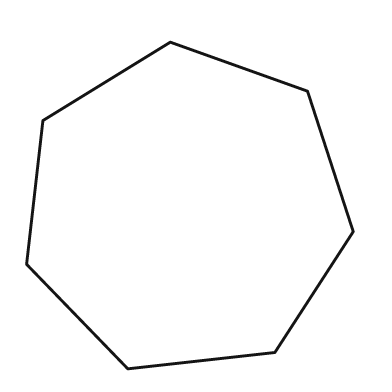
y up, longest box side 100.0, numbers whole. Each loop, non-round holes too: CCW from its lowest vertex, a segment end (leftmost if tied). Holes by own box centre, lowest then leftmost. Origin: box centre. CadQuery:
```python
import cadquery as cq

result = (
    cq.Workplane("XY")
    .moveTo(-19.0, -50.0)
    .lineTo(26.0, -45.0)
    .lineTo(50.0, -8.0)
    .lineTo(36.0, 35.0)
    .lineTo(-6.0, 50.0)
    .lineTo(-45.0, 26.0)
    .lineTo(-50.0, -18.0)
    .close()
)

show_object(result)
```